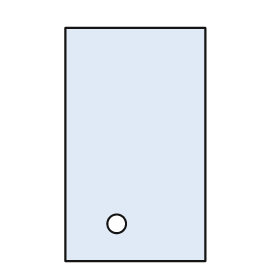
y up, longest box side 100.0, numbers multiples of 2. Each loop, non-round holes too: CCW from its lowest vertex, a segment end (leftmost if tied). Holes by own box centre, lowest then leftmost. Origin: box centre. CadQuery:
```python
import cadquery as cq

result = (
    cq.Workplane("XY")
    .moveTo(-30.0, -50.0)
    .lineTo(30.0, -50.0)
    .lineTo(30.0, 50.0)
    .lineTo(-30.0, 50.0)
    .close()
    .moveTo(-8.0, -34.0)
    .circle(4.0)
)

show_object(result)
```